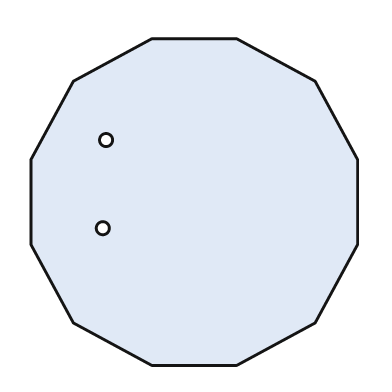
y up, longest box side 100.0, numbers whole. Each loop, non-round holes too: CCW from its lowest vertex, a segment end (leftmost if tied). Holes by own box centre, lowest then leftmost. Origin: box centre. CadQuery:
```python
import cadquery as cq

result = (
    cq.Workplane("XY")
    .moveTo(-13.0, -50.0)
    .lineTo(13.0, -50.0)
    .lineTo(37.0, -37.0)
    .lineTo(50.0, -13.0)
    .lineTo(50.0, 13.0)
    .lineTo(37.0, 37.0)
    .lineTo(13.0, 50.0)
    .lineTo(-13.0, 50.0)
    .lineTo(-37.0, 37.0)
    .lineTo(-50.0, 13.0)
    .lineTo(-50.0, -13.0)
    .lineTo(-37.0, -37.0)
    .close()
    .moveTo(-28.0, -8.0)
    .circle(2.0)
    .moveTo(-27.0, 19.0)
    .circle(2.0)
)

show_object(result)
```